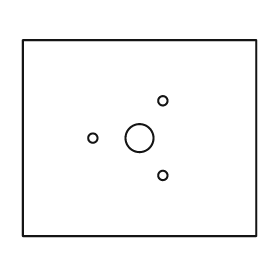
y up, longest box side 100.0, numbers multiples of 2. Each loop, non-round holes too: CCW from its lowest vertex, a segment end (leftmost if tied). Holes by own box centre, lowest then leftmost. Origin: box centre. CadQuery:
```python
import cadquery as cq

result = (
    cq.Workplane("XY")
    .moveTo(-50.0, -42.0)
    .lineTo(50.0, -42.0)
    .lineTo(50.0, 42.0)
    .lineTo(-50.0, 42.0)
    .close()
    .moveTo(10.0, -16.0)
    .circle(2.0)
    .moveTo(-20.0, 0.0)
    .circle(2.0)
    .moveTo(0.0, 0.0)
    .circle(6.0)
    .moveTo(10.0, 16.0)
    .circle(2.0)
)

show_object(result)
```